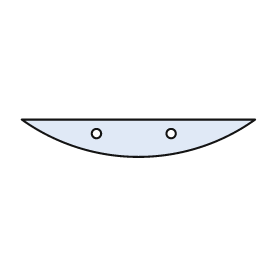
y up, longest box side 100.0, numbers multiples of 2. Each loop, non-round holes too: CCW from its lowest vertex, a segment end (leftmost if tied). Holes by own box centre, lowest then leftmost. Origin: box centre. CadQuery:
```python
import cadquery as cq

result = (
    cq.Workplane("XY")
    .moveTo(-50.0, 8.0)
    .threePointArc((0.0, -8.0), (50.0, 8.0))
    .close()
    .moveTo(-18.0, 2.0)
    .circle(2.0)
    .moveTo(14.0, 2.0)
    .circle(2.0)
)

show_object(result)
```